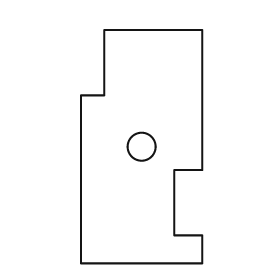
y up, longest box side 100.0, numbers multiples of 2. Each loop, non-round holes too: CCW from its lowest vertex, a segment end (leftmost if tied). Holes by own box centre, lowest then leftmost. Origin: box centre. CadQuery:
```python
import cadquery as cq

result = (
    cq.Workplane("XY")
    .moveTo(-26.0, -50.0)
    .lineTo(26.0, -50.0)
    .lineTo(26.0, -38.0)
    .lineTo(14.0, -38.0)
    .lineTo(14.0, -10.0)
    .lineTo(26.0, -10.0)
    .lineTo(26.0, 50.0)
    .lineTo(-16.0, 50.0)
    .lineTo(-16.0, 22.0)
    .lineTo(-26.0, 22.0)
    .close()
    .moveTo(0.0, 0.0)
    .circle(6.0)
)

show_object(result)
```